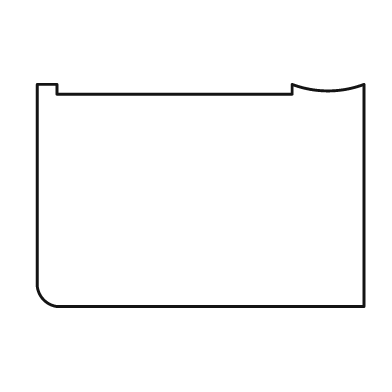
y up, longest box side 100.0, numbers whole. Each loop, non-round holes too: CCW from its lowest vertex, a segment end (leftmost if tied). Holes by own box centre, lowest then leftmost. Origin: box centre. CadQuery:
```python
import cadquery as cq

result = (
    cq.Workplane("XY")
    .moveTo(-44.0, -34.0)
    .lineTo(50.0, -34.0)
    .lineTo(50.0, 34.0)
    .threePointArc((39.0, 32.0), (28.0, 34.0))
    .lineTo(28.0, 31.0)
    .lineTo(-44.0, 31.0)
    .lineTo(-44.0, 34.0)
    .lineTo(-50.0, 34.0)
    .lineTo(-50.0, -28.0)
    .threePointArc((-48.0, -32.0), (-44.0, -34.0))
    .close()
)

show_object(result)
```